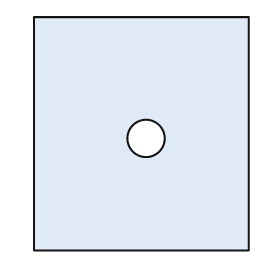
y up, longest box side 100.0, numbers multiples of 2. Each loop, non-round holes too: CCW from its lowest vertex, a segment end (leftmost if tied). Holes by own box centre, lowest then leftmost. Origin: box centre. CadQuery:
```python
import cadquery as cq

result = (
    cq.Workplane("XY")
    .moveTo(-46.0, -50.0)
    .lineTo(46.0, -50.0)
    .lineTo(46.0, 50.0)
    .lineTo(-46.0, 50.0)
    .close()
    .moveTo(2.0, -2.0)
    .circle(8.0)
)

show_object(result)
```